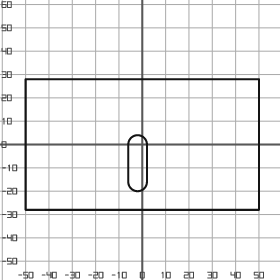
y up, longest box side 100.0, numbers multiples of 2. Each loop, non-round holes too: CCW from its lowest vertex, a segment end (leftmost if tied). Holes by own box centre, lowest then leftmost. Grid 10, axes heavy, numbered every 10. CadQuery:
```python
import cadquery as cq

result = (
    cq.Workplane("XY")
    .moveTo(-50.0, -28.0)
    .lineTo(50.0, -28.0)
    .lineTo(50.0, 28.0)
    .lineTo(-50.0, 28.0)
    .close()
    .moveTo(-6.0, -16.0)
    .threePointArc((-2.0, -20.0), (2.0, -16.0))
    .lineTo(2.0, 0.0)
    .threePointArc((-2.0, 4.0), (-6.0, 0.0))
    .close()
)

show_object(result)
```